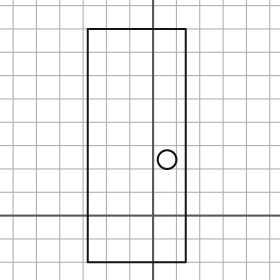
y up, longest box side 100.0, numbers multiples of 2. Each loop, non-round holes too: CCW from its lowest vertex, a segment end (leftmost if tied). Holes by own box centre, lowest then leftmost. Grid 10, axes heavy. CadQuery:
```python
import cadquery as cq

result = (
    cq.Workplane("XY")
    .moveTo(-28.0, -20.0)
    .lineTo(14.0, -20.0)
    .lineTo(14.0, 80.0)
    .lineTo(-28.0, 80.0)
    .close()
    .moveTo(6.0, 24.0)
    .circle(4.0)
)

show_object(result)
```